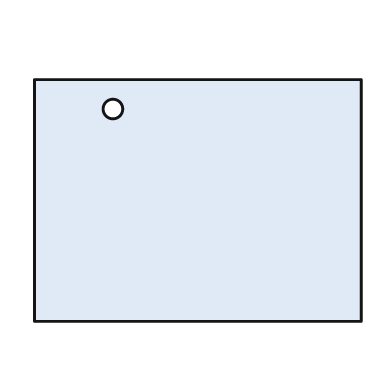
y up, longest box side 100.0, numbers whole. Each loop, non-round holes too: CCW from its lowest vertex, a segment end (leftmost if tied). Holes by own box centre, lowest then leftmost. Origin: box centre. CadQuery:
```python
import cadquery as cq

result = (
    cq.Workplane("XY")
    .moveTo(-50.0, -37.0)
    .lineTo(50.0, -37.0)
    .lineTo(50.0, 37.0)
    .lineTo(-50.0, 37.0)
    .close()
    .moveTo(-26.0, 28.0)
    .circle(3.0)
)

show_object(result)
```